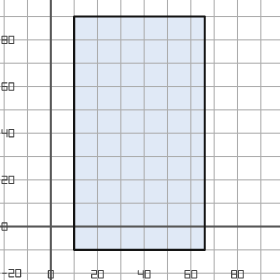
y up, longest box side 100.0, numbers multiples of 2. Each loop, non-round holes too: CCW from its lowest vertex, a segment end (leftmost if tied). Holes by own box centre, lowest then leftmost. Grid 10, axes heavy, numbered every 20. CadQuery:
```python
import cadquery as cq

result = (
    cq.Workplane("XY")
    .moveTo(10.0, -10.0)
    .lineTo(66.0, -10.0)
    .lineTo(66.0, 90.0)
    .lineTo(10.0, 90.0)
    .close()
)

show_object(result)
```